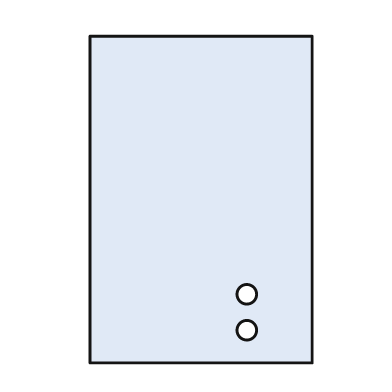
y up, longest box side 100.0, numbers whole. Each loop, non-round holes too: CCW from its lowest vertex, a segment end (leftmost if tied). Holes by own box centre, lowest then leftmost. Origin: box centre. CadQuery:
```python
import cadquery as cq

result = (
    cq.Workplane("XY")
    .moveTo(-34.0, -50.0)
    .lineTo(34.0, -50.0)
    .lineTo(34.0, 50.0)
    .lineTo(-34.0, 50.0)
    .close()
    .moveTo(14.0, -40.0)
    .circle(3.0)
    .moveTo(14.0, -29.0)
    .circle(3.0)
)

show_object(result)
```